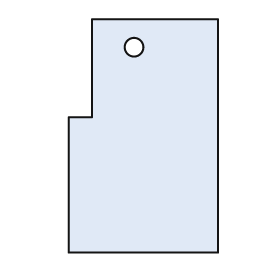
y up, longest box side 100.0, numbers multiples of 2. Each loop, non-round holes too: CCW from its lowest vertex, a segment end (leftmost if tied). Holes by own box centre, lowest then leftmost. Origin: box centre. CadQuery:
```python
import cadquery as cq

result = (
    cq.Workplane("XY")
    .moveTo(-32.0, -50.0)
    .lineTo(32.0, -50.0)
    .lineTo(32.0, 50.0)
    .lineTo(-22.0, 50.0)
    .lineTo(-22.0, 8.0)
    .lineTo(-32.0, 8.0)
    .close()
    .moveTo(-4.0, 38.0)
    .circle(4.0)
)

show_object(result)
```